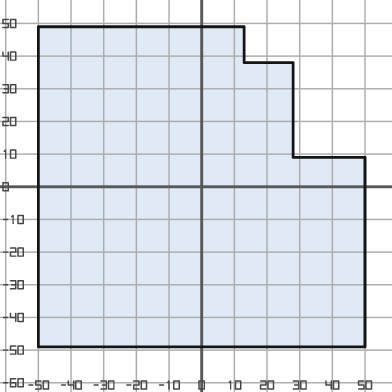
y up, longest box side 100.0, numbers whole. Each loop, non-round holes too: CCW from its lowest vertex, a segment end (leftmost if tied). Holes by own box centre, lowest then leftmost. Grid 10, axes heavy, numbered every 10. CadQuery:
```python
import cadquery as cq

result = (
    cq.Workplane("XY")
    .moveTo(-50.0, -49.0)
    .lineTo(50.0, -49.0)
    .lineTo(50.0, 9.0)
    .lineTo(28.0, 9.0)
    .lineTo(28.0, 38.0)
    .lineTo(13.0, 38.0)
    .lineTo(13.0, 49.0)
    .lineTo(-50.0, 49.0)
    .close()
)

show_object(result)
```